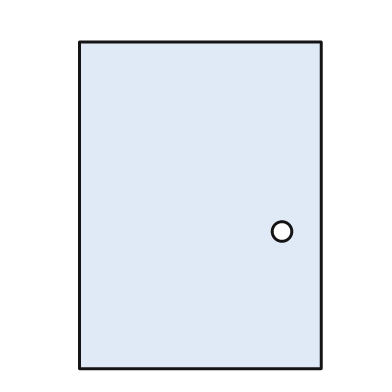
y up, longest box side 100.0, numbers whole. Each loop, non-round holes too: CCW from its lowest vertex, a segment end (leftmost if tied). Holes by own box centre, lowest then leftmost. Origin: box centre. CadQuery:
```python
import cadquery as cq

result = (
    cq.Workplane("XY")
    .moveTo(-37.0, -50.0)
    .lineTo(37.0, -50.0)
    .lineTo(37.0, 50.0)
    .lineTo(-37.0, 50.0)
    .close()
    .moveTo(25.0, -8.0)
    .circle(3.0)
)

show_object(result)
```